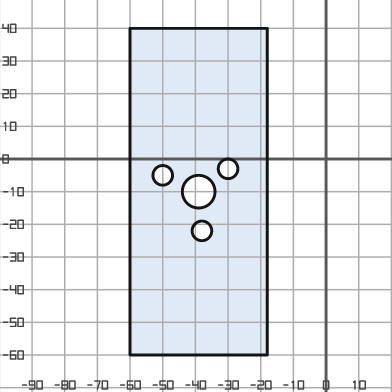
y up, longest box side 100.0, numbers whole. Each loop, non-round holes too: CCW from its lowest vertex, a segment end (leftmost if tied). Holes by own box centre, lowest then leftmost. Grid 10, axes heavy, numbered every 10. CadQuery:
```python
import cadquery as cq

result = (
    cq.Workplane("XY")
    .moveTo(-60.0, -60.0)
    .lineTo(-18.0, -60.0)
    .lineTo(-18.0, 40.0)
    .lineTo(-60.0, 40.0)
    .close()
    .moveTo(-38.0, -22.0)
    .circle(3.0)
    .moveTo(-39.0, -10.0)
    .circle(5.0)
    .moveTo(-50.0, -5.0)
    .circle(3.0)
    .moveTo(-30.0, -3.0)
    .circle(3.0)
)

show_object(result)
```